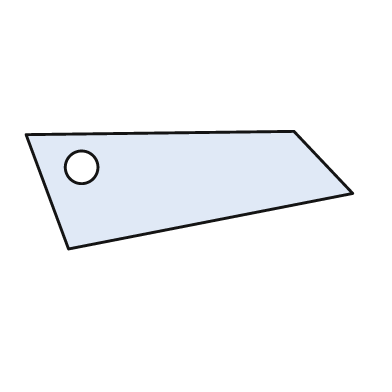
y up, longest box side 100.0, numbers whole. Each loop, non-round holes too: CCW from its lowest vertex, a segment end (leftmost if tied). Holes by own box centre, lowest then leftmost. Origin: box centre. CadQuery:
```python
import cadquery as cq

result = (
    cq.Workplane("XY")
    .moveTo(-37.0, -18.0)
    .lineTo(50.0, -1.0)
    .lineTo(32.0, 18.0)
    .lineTo(-50.0, 17.0)
    .close()
    .moveTo(-33.0, 7.0)
    .circle(5.0)
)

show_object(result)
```